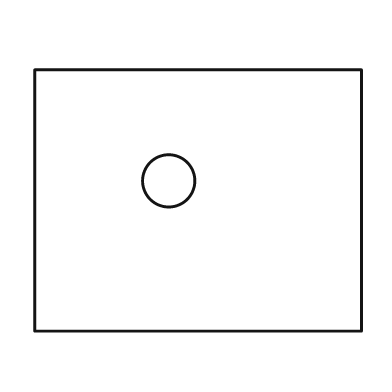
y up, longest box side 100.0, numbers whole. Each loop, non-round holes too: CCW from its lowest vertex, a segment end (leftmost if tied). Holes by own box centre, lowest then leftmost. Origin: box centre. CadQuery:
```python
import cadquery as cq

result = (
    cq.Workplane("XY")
    .moveTo(-50.0, -40.0)
    .lineTo(50.0, -40.0)
    .lineTo(50.0, 40.0)
    .lineTo(-50.0, 40.0)
    .close()
    .moveTo(-9.0, 6.0)
    .circle(8.0)
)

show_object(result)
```